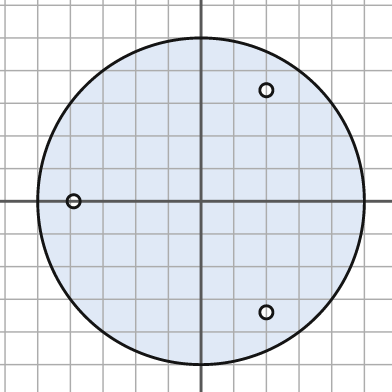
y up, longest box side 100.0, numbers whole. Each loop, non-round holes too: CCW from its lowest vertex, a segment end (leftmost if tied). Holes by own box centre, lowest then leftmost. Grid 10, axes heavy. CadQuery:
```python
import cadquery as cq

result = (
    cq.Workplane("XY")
    .moveTo(0.0, 0.0)
    .circle(50.0)
    .moveTo(20.0, -34.0)
    .circle(2.0)
    .moveTo(-39.0, 0.0)
    .circle(2.0)
    .moveTo(20.0, 34.0)
    .circle(2.0)
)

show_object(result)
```